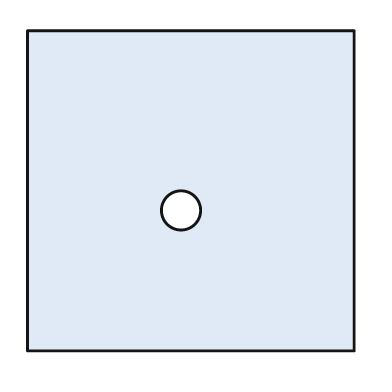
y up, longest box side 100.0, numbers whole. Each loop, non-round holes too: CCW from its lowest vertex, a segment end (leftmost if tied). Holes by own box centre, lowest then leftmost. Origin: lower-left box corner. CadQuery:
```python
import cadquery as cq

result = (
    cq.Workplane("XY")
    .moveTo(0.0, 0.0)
    .lineTo(100.0, 0.0)
    .lineTo(100.0, 98.0)
    .lineTo(0.0, 98.0)
    .close()
    .moveTo(47.0, 43.0)
    .circle(6.0)
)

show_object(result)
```